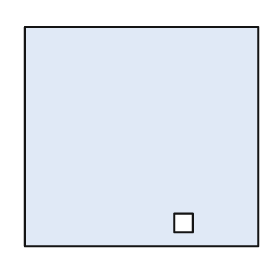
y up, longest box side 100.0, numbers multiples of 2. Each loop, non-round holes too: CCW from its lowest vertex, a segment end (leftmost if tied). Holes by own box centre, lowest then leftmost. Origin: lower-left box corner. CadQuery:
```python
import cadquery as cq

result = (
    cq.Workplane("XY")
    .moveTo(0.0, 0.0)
    .lineTo(100.0, 0.0)
    .lineTo(100.0, 94.0)
    .lineTo(0.0, 94.0)
    .close()
    .moveTo(64.0, 6.0)
    .lineTo(72.0, 6.0)
    .lineTo(72.0, 14.0)
    .lineTo(64.0, 14.0)
    .close()
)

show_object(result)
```